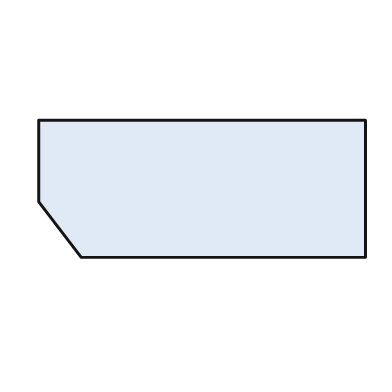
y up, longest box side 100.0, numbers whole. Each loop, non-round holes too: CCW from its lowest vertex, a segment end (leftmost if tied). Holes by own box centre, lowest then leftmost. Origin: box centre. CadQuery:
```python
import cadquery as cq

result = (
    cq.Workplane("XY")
    .moveTo(-37.0, -21.0)
    .lineTo(50.0, -21.0)
    .lineTo(50.0, 21.0)
    .lineTo(-50.0, 21.0)
    .lineTo(-50.0, -4.0)
    .close()
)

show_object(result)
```